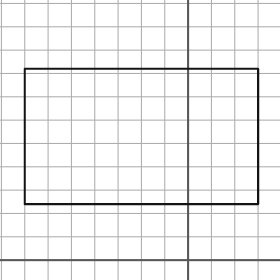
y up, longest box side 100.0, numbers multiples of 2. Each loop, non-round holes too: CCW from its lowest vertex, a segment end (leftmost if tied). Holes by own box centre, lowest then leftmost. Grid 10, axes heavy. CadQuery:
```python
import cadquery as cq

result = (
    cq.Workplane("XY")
    .moveTo(-70.0, 24.0)
    .lineTo(30.0, 24.0)
    .lineTo(30.0, 82.0)
    .lineTo(-70.0, 82.0)
    .close()
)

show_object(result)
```